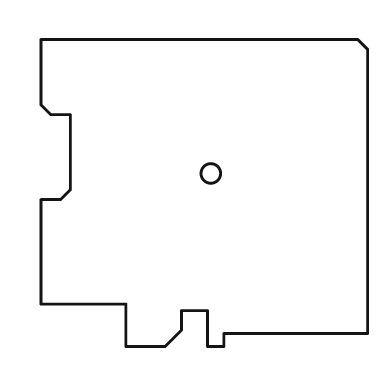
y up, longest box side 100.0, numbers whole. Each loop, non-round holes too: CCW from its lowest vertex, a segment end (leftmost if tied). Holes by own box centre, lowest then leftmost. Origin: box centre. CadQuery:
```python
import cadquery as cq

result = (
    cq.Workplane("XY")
    .moveTo(-24.0, -47.0)
    .lineTo(-12.0, -47.0)
    .lineTo(-7.0, -42.0)
    .lineTo(-7.0, -36.0)
    .lineTo(1.0, -36.0)
    .lineTo(1.0, -47.0)
    .lineTo(6.0, -47.0)
    .lineTo(6.0, -43.0)
    .lineTo(50.0, -43.0)
    .lineTo(50.0, 44.0)
    .lineTo(47.0, 47.0)
    .lineTo(-50.0, 47.0)
    .lineTo(-50.0, 27.0)
    .lineTo(-47.0, 24.0)
    .lineTo(-41.0, 24.0)
    .lineTo(-41.0, 1.0)
    .lineTo(-44.0, -2.0)
    .lineTo(-50.0, -2.0)
    .lineTo(-50.0, -34.0)
    .lineTo(-24.0, -34.0)
    .close()
    .moveTo(2.0, 6.0)
    .circle(3.0)
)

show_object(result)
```